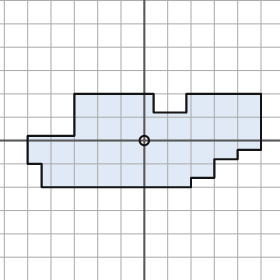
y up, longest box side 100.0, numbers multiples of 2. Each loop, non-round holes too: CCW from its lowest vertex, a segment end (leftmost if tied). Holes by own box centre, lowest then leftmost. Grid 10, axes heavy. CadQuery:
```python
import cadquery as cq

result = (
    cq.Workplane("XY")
    .moveTo(-44.0, -20.0)
    .lineTo(20.0, -20.0)
    .lineTo(20.0, -16.0)
    .lineTo(30.0, -16.0)
    .lineTo(30.0, -8.0)
    .lineTo(40.0, -8.0)
    .lineTo(40.0, -4.0)
    .lineTo(50.0, -4.0)
    .lineTo(50.0, 20.0)
    .lineTo(18.0, 20.0)
    .lineTo(18.0, 12.0)
    .lineTo(4.0, 12.0)
    .lineTo(4.0, 20.0)
    .lineTo(-30.0, 20.0)
    .lineTo(-30.0, 2.0)
    .lineTo(-50.0, 2.0)
    .lineTo(-50.0, -10.0)
    .lineTo(-44.0, -10.0)
    .close()
    .moveTo(0.0, 0.0)
    .circle(2.0)
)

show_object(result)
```